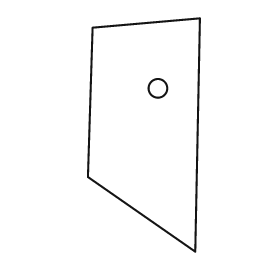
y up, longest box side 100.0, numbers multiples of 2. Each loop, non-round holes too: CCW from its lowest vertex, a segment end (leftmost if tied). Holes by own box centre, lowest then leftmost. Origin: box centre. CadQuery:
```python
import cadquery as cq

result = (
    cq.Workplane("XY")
    .moveTo(22.0, -50.0)
    .lineTo(24.0, 50.0)
    .lineTo(-22.0, 46.0)
    .lineTo(-24.0, -18.0)
    .close()
    .moveTo(6.0, 20.0)
    .circle(4.0)
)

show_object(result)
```